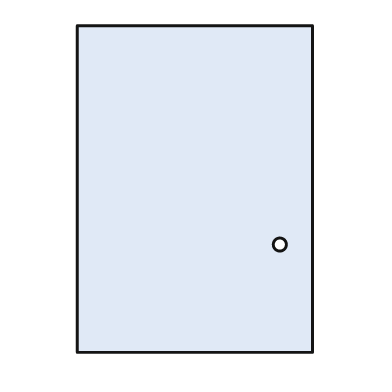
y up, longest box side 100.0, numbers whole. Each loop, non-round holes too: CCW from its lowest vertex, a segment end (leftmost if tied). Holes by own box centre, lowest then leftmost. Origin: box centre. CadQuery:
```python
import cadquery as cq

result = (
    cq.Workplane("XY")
    .moveTo(-36.0, -50.0)
    .lineTo(36.0, -50.0)
    .lineTo(36.0, 50.0)
    .lineTo(-36.0, 50.0)
    .close()
    .moveTo(26.0, -17.0)
    .circle(2.0)
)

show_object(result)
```